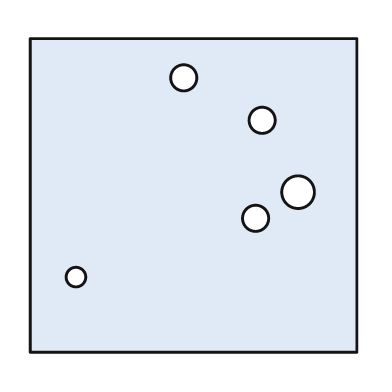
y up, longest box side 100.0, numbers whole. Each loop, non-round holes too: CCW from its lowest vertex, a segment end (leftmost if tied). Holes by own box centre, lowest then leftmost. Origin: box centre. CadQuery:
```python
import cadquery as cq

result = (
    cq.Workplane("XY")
    .moveTo(-50.0, -48.0)
    .lineTo(50.0, -48.0)
    .lineTo(50.0, 48.0)
    .lineTo(-50.0, 48.0)
    .close()
    .moveTo(-36.0, -25.0)
    .circle(3.0)
    .moveTo(19.0, -7.0)
    .circle(4.0)
    .moveTo(32.0, 1.0)
    .circle(5.0)
    .moveTo(21.0, 23.0)
    .circle(4.0)
    .moveTo(-3.0, 36.0)
    .circle(4.0)
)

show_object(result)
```